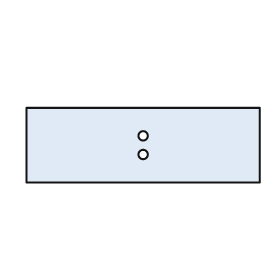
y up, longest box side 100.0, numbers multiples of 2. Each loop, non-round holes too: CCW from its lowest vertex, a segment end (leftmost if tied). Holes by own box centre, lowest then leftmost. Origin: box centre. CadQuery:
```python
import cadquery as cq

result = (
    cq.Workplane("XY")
    .moveTo(-50.0, -16.0)
    .lineTo(50.0, -16.0)
    .lineTo(50.0, 16.0)
    .lineTo(-50.0, 16.0)
    .close()
    .moveTo(0.0, -4.0)
    .circle(2.0)
    .moveTo(0.0, 4.0)
    .circle(2.0)
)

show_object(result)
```